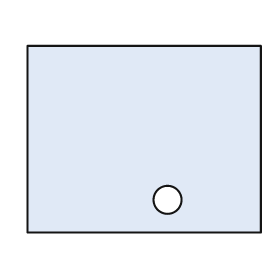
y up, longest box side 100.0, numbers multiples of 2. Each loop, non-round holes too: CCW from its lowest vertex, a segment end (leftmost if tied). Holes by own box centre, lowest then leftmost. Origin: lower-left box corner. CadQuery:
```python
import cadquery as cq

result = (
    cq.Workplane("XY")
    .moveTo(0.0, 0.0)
    .lineTo(100.0, 0.0)
    .lineTo(100.0, 80.0)
    .lineTo(0.0, 80.0)
    .close()
    .moveTo(60.0, 14.0)
    .circle(6.0)
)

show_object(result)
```